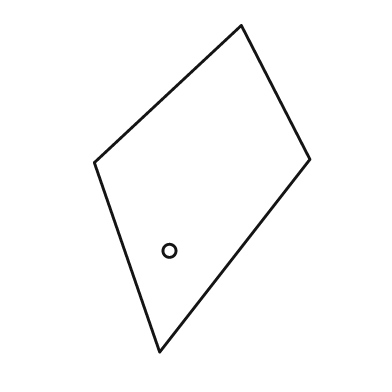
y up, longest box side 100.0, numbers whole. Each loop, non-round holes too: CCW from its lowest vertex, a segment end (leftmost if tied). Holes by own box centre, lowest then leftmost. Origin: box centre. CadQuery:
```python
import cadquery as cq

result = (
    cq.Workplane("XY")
    .moveTo(-13.0, -50.0)
    .lineTo(33.0, 9.0)
    .lineTo(12.0, 50.0)
    .lineTo(-33.0, 8.0)
    .close()
    .moveTo(-10.0, -19.0)
    .circle(2.0)
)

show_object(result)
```